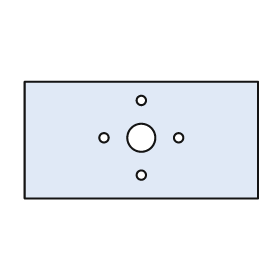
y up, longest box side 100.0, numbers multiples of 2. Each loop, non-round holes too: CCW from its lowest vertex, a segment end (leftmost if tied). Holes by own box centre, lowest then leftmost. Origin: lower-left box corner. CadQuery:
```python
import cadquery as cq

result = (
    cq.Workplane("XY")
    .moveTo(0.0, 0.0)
    .lineTo(100.0, 0.0)
    .lineTo(100.0, 50.0)
    .lineTo(0.0, 50.0)
    .close()
    .moveTo(50.0, 10.0)
    .circle(2.0)
    .moveTo(34.0, 26.0)
    .circle(2.0)
    .moveTo(50.0, 26.0)
    .circle(6.0)
    .moveTo(66.0, 26.0)
    .circle(2.0)
    .moveTo(50.0, 42.0)
    .circle(2.0)
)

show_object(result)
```